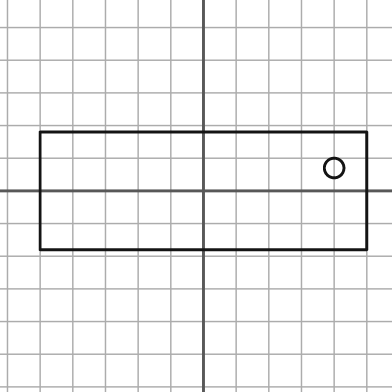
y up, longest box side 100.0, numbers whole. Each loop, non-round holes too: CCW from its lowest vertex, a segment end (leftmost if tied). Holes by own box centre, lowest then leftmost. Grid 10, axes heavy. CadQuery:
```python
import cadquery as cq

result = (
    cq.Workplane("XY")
    .moveTo(-50.0, -18.0)
    .lineTo(50.0, -18.0)
    .lineTo(50.0, 18.0)
    .lineTo(-50.0, 18.0)
    .close()
    .moveTo(40.0, 7.0)
    .circle(3.0)
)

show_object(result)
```